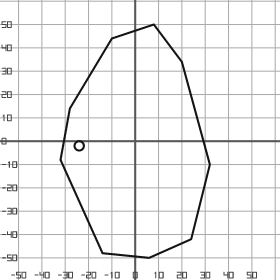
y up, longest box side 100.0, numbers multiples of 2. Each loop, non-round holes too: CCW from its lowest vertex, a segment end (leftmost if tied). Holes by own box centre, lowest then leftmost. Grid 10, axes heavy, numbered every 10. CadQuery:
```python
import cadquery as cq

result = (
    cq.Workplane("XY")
    .moveTo(6.0, -50.0)
    .lineTo(24.0, -42.0)
    .lineTo(32.0, -10.0)
    .lineTo(20.0, 34.0)
    .lineTo(8.0, 50.0)
    .lineTo(-10.0, 44.0)
    .lineTo(-28.0, 14.0)
    .lineTo(-32.0, -8.0)
    .lineTo(-14.0, -48.0)
    .close()
    .moveTo(-24.0, -2.0)
    .circle(2.0)
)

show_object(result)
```